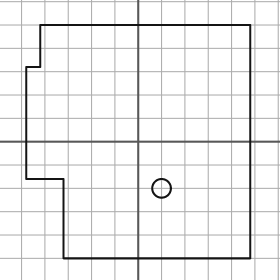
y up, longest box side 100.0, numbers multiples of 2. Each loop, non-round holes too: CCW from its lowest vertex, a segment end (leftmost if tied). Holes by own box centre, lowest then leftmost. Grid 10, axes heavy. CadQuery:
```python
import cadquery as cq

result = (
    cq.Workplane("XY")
    .moveTo(-32.0, -50.0)
    .lineTo(48.0, -50.0)
    .lineTo(48.0, 50.0)
    .lineTo(-42.0, 50.0)
    .lineTo(-42.0, 32.0)
    .lineTo(-48.0, 32.0)
    .lineTo(-48.0, -16.0)
    .lineTo(-32.0, -16.0)
    .close()
    .moveTo(10.0, -20.0)
    .circle(4.0)
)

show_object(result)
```